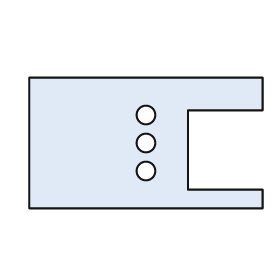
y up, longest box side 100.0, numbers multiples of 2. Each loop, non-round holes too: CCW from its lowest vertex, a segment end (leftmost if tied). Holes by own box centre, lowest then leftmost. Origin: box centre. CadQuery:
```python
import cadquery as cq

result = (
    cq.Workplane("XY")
    .moveTo(-50.0, -28.0)
    .lineTo(50.0, -28.0)
    .lineTo(50.0, -20.0)
    .lineTo(18.0, -20.0)
    .lineTo(18.0, 14.0)
    .lineTo(50.0, 14.0)
    .lineTo(50.0, 28.0)
    .lineTo(-50.0, 28.0)
    .close()
    .moveTo(0.0, -12.0)
    .circle(4.0)
    .moveTo(0.0, 0.0)
    .circle(4.0)
    .moveTo(0.0, 12.0)
    .circle(4.0)
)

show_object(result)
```